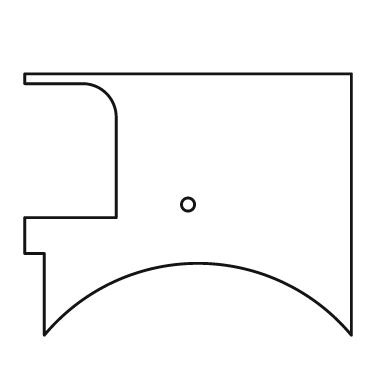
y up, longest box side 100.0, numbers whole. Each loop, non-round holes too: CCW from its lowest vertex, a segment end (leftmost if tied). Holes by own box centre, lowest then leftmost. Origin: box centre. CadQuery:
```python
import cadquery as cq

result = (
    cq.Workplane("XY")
    .moveTo(-44.0, -40.0)
    .threePointArc((3.0, -18.0), (50.0, -40.0))
    .lineTo(50.0, 40.0)
    .lineTo(-50.0, 40.0)
    .lineTo(-50.0, 37.0)
    .lineTo(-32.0, 37.0)
    .threePointArc((-25.0, 34.0), (-22.0, 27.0))
    .lineTo(-22.0, -4.0)
    .lineTo(-50.0, -4.0)
    .lineTo(-50.0, -15.0)
    .lineTo(-44.0, -15.0)
    .close()
    .moveTo(0.0, 0.0)
    .circle(2.0)
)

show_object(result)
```